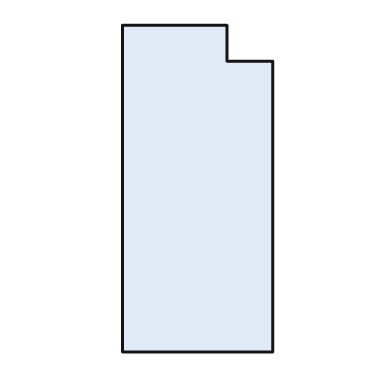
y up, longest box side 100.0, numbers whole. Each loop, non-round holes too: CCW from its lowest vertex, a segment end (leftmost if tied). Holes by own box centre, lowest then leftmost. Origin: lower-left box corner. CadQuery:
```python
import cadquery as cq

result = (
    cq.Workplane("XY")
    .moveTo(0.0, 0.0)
    .lineTo(46.0, 0.0)
    .lineTo(46.0, 89.0)
    .lineTo(32.0, 89.0)
    .lineTo(32.0, 100.0)
    .lineTo(0.0, 100.0)
    .close()
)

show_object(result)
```